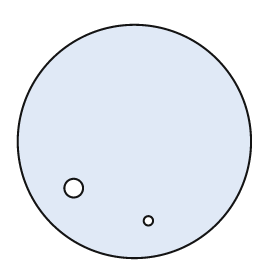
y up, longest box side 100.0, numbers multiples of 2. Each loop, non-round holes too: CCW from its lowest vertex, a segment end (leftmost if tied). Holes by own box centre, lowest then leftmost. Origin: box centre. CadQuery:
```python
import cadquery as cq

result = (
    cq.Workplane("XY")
    .moveTo(0.0, 0.0)
    .circle(50.0)
    .moveTo(6.0, -34.0)
    .circle(2.0)
    .moveTo(-26.0, -20.0)
    .circle(4.0)
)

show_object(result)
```